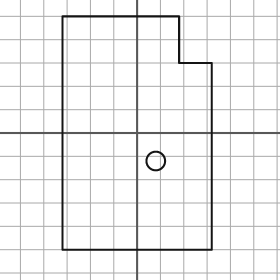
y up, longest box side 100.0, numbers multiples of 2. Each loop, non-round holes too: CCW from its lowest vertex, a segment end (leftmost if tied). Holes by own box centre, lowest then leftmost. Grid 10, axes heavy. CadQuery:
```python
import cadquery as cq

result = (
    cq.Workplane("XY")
    .moveTo(-32.0, -50.0)
    .lineTo(32.0, -50.0)
    .lineTo(32.0, 30.0)
    .lineTo(18.0, 30.0)
    .lineTo(18.0, 50.0)
    .lineTo(-32.0, 50.0)
    .close()
    .moveTo(8.0, -12.0)
    .circle(4.0)
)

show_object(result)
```